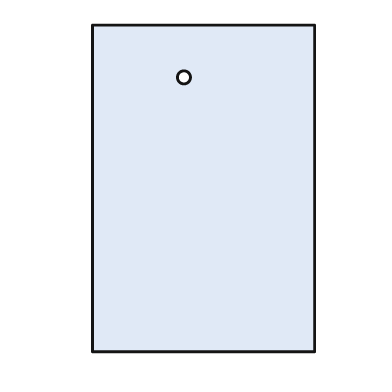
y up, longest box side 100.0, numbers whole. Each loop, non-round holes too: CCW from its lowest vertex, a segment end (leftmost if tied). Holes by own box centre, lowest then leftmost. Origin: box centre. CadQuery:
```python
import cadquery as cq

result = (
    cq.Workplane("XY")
    .moveTo(-34.0, -50.0)
    .lineTo(34.0, -50.0)
    .lineTo(34.0, 50.0)
    .lineTo(-34.0, 50.0)
    .close()
    .moveTo(-6.0, 34.0)
    .circle(2.0)
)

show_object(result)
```